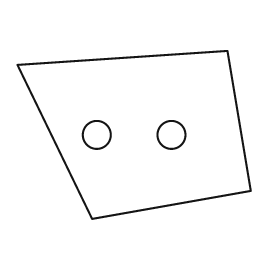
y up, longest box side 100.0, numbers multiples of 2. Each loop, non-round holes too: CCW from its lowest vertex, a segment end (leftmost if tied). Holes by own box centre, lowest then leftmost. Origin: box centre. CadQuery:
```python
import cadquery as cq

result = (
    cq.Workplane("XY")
    .moveTo(-18.0, -36.0)
    .lineTo(50.0, -24.0)
    .lineTo(40.0, 36.0)
    .lineTo(-50.0, 30.0)
    .close()
    .moveTo(-16.0, 0.0)
    .circle(6.0)
    .moveTo(16.0, 0.0)
    .circle(6.0)
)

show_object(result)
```